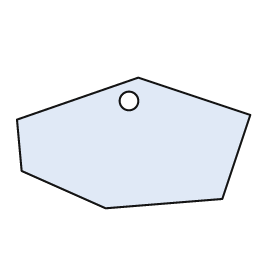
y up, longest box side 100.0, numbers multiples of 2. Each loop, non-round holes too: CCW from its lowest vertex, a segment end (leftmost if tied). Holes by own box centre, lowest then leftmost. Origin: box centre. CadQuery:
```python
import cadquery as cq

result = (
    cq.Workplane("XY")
    .moveTo(-12.0, -28.0)
    .lineTo(38.0, -24.0)
    .lineTo(50.0, 12.0)
    .lineTo(2.0, 28.0)
    .lineTo(-50.0, 10.0)
    .lineTo(-48.0, -12.0)
    .close()
    .moveTo(-2.0, 18.0)
    .circle(4.0)
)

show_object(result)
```